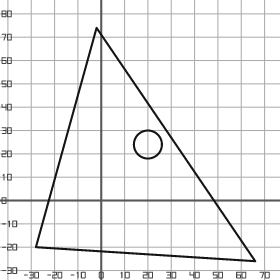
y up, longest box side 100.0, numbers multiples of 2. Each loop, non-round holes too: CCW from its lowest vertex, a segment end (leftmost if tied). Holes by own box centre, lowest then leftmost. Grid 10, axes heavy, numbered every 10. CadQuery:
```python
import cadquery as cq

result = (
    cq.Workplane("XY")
    .moveTo(66.0, -26.0)
    .lineTo(-2.0, 74.0)
    .lineTo(-28.0, -20.0)
    .close()
    .moveTo(20.0, 24.0)
    .circle(6.0)
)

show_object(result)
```